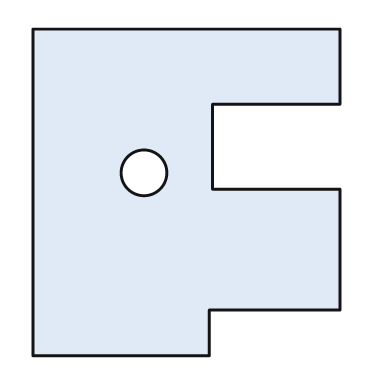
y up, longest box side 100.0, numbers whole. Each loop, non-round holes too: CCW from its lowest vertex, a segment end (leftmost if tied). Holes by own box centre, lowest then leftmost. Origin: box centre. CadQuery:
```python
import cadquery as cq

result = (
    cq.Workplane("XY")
    .moveTo(-47.0, -50.0)
    .lineTo(7.0, -50.0)
    .lineTo(7.0, -36.0)
    .lineTo(47.0, -36.0)
    .lineTo(47.0, 1.0)
    .lineTo(8.0, 1.0)
    .lineTo(8.0, 27.0)
    .lineTo(47.0, 27.0)
    .lineTo(47.0, 50.0)
    .lineTo(-47.0, 50.0)
    .close()
    .moveTo(-13.0, 6.0)
    .circle(7.0)
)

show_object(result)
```